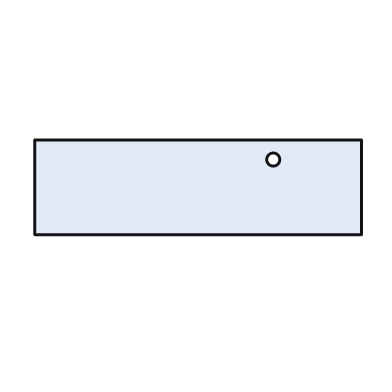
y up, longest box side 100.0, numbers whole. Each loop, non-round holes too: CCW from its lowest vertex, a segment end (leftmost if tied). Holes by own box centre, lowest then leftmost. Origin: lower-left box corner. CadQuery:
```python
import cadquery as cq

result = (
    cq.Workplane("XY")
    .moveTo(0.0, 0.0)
    .lineTo(100.0, 0.0)
    .lineTo(100.0, 29.0)
    .lineTo(0.0, 29.0)
    .close()
    .moveTo(73.0, 23.0)
    .circle(2.0)
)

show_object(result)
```